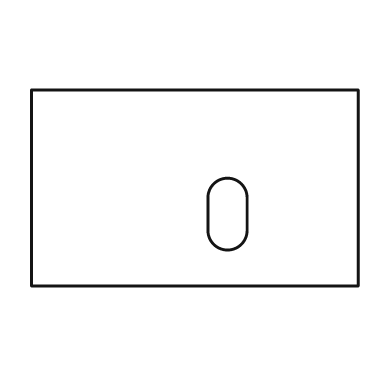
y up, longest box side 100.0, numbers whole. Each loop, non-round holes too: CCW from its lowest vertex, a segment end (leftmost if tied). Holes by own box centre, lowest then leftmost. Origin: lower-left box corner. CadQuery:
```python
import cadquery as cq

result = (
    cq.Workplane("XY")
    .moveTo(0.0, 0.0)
    .lineTo(100.0, 0.0)
    .lineTo(100.0, 60.0)
    .lineTo(0.0, 60.0)
    .close()
    .moveTo(54.0, 17.0)
    .threePointArc((60.0, 11.0), (66.0, 17.0))
    .lineTo(66.0, 27.0)
    .threePointArc((60.0, 33.0), (54.0, 27.0))
    .close()
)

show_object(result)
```